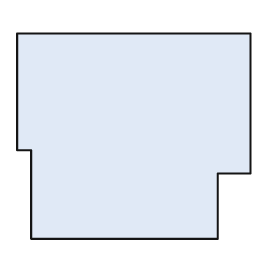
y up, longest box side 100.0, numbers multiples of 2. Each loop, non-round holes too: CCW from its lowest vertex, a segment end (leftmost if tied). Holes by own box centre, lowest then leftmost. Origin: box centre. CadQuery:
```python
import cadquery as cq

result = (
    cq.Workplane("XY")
    .moveTo(-44.0, -44.0)
    .lineTo(36.0, -44.0)
    .lineTo(36.0, -16.0)
    .lineTo(50.0, -16.0)
    .lineTo(50.0, 44.0)
    .lineTo(-50.0, 44.0)
    .lineTo(-50.0, -6.0)
    .lineTo(-44.0, -6.0)
    .close()
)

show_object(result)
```